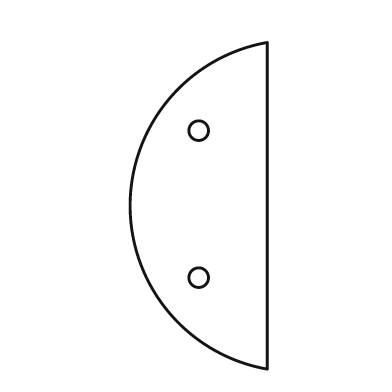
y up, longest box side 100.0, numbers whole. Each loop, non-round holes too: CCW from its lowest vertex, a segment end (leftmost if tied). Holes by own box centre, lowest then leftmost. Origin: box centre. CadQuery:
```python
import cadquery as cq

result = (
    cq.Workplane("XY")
    .moveTo(21.0, -50.0)
    .lineTo(21.0, 50.0)
    .threePointArc((-21.0, 0.0), (21.0, -50.0))
    .close()
    .moveTo(0.0, -22.0)
    .circle(3.0)
    .moveTo(0.0, 23.0)
    .circle(3.0)
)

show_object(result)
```